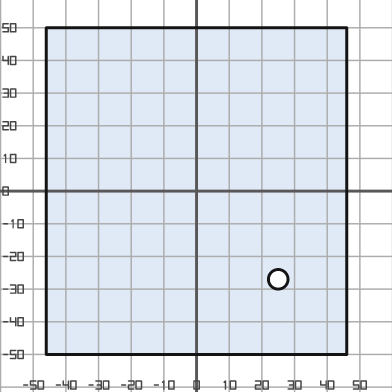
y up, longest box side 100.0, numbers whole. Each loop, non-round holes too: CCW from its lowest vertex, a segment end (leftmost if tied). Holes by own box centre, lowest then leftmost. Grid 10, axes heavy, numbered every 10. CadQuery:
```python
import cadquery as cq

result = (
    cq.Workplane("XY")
    .moveTo(-46.0, -50.0)
    .lineTo(46.0, -50.0)
    .lineTo(46.0, 50.0)
    .lineTo(-46.0, 50.0)
    .close()
    .moveTo(25.0, -27.0)
    .circle(3.0)
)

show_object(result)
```